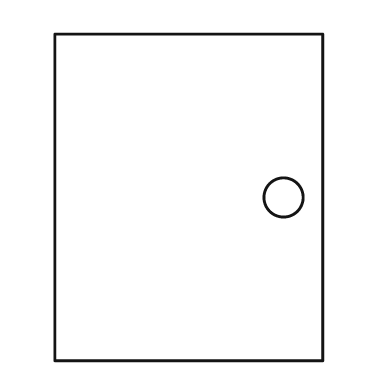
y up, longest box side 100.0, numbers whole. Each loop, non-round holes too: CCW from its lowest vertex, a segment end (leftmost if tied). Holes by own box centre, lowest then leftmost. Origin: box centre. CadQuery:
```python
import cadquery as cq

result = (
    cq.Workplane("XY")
    .moveTo(-41.0, -50.0)
    .lineTo(41.0, -50.0)
    .lineTo(41.0, 50.0)
    .lineTo(-41.0, 50.0)
    .close()
    .moveTo(29.0, 0.0)
    .circle(6.0)
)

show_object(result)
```